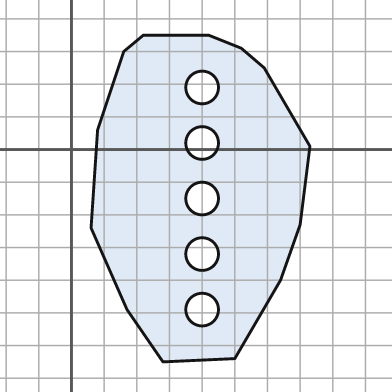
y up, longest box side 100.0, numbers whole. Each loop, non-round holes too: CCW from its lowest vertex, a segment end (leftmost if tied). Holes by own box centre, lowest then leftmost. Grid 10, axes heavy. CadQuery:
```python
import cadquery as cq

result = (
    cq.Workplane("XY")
    .moveTo(28.0, -65.0)
    .lineTo(50.0, -64.0)
    .lineTo(64.0, -40.0)
    .lineTo(70.0, -23.0)
    .lineTo(73.0, 1.0)
    .lineTo(59.0, 25.0)
    .lineTo(52.0, 31.0)
    .lineTo(42.0, 35.0)
    .lineTo(22.0, 35.0)
    .lineTo(16.0, 30.0)
    .lineTo(8.0, 6.0)
    .lineTo(6.0, -24.0)
    .lineTo(17.0, -49.0)
    .close()
    .moveTo(40.0, -49.0)
    .circle(5.0)
    .moveTo(40.0, -32.0)
    .circle(5.0)
    .moveTo(40.0, -15.0)
    .circle(5.0)
    .moveTo(40.0, 2.0)
    .circle(5.0)
    .moveTo(40.0, 19.0)
    .circle(5.0)
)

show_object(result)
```